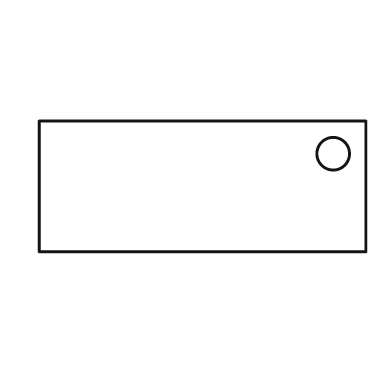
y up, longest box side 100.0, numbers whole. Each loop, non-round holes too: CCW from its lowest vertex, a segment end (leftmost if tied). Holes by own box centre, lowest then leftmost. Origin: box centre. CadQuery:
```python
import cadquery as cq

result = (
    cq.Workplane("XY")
    .moveTo(-50.0, -20.0)
    .lineTo(50.0, -20.0)
    .lineTo(50.0, 20.0)
    .lineTo(-50.0, 20.0)
    .close()
    .moveTo(40.0, 10.0)
    .circle(5.0)
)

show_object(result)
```